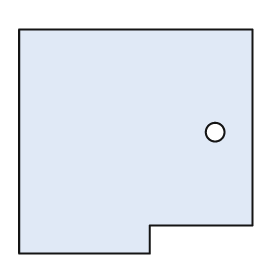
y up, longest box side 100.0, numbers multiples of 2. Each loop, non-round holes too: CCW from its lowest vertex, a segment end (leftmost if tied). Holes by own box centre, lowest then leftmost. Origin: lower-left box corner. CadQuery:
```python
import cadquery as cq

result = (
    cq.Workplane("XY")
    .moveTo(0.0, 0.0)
    .lineTo(56.0, 0.0)
    .lineTo(56.0, 12.0)
    .lineTo(100.0, 12.0)
    .lineTo(100.0, 96.0)
    .lineTo(0.0, 96.0)
    .close()
    .moveTo(84.0, 52.0)
    .circle(4.0)
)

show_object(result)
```